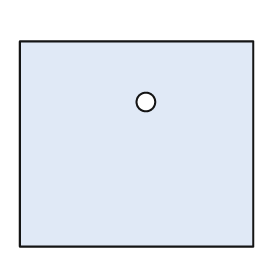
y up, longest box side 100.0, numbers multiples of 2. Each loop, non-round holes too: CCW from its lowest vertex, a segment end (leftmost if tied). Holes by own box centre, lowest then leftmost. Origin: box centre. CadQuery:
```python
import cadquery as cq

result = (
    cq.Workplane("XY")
    .moveTo(-50.0, -44.0)
    .lineTo(50.0, -44.0)
    .lineTo(50.0, 44.0)
    .lineTo(-50.0, 44.0)
    .close()
    .moveTo(4.0, 18.0)
    .circle(4.0)
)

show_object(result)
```